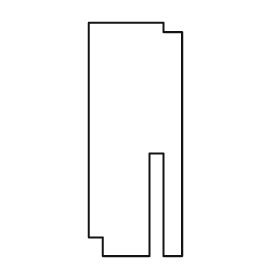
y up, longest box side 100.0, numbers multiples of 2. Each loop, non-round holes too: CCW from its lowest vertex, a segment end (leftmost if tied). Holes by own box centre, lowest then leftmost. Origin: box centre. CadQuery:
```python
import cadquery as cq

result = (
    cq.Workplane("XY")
    .moveTo(-14.0, -50.0)
    .lineTo(6.0, -50.0)
    .lineTo(6.0, -6.0)
    .lineTo(12.0, -6.0)
    .lineTo(12.0, -50.0)
    .lineTo(20.0, -50.0)
    .lineTo(20.0, 46.0)
    .lineTo(12.0, 46.0)
    .lineTo(12.0, 50.0)
    .lineTo(-20.0, 50.0)
    .lineTo(-20.0, -42.0)
    .lineTo(-14.0, -42.0)
    .close()
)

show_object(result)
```